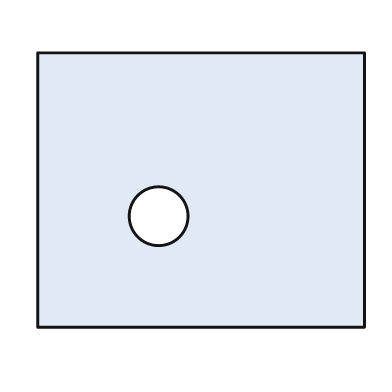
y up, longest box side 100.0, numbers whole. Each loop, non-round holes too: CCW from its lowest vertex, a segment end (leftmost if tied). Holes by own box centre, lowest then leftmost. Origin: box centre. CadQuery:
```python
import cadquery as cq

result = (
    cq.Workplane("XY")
    .moveTo(-50.0, -42.0)
    .lineTo(50.0, -42.0)
    .lineTo(50.0, 42.0)
    .lineTo(-50.0, 42.0)
    .close()
    .moveTo(-13.0, -8.0)
    .circle(9.0)
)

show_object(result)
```